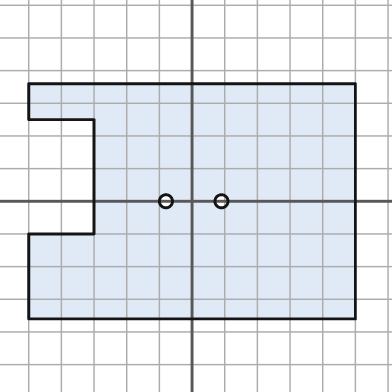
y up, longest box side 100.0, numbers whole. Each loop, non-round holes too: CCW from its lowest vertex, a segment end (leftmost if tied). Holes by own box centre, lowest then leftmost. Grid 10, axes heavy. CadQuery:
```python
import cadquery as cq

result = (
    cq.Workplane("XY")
    .moveTo(-50.0, -36.0)
    .lineTo(50.0, -36.0)
    .lineTo(50.0, 36.0)
    .lineTo(-50.0, 36.0)
    .lineTo(-50.0, 25.0)
    .lineTo(-30.0, 25.0)
    .lineTo(-30.0, -10.0)
    .lineTo(-50.0, -10.0)
    .close()
    .moveTo(-8.0, 0.0)
    .circle(2.0)
    .moveTo(9.0, 0.0)
    .circle(2.0)
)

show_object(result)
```